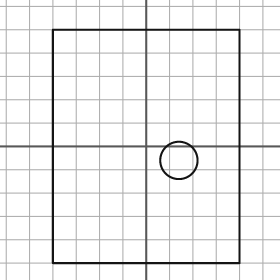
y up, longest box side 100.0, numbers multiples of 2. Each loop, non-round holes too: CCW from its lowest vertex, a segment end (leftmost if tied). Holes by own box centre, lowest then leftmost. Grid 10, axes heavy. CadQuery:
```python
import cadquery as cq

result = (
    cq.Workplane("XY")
    .moveTo(-40.0, -50.0)
    .lineTo(40.0, -50.0)
    .lineTo(40.0, 50.0)
    .lineTo(-40.0, 50.0)
    .close()
    .moveTo(14.0, -6.0)
    .circle(8.0)
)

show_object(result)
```